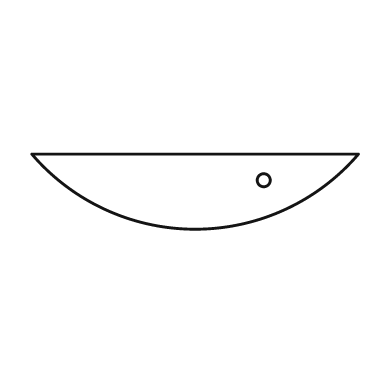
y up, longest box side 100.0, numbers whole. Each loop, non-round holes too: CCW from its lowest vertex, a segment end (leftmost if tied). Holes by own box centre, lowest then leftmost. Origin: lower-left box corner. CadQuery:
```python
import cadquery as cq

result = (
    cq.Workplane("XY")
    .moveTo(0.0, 23.0)
    .threePointArc((50.0, 0.0), (100.0, 23.0))
    .close()
    .moveTo(71.0, 15.0)
    .circle(2.0)
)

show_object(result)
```